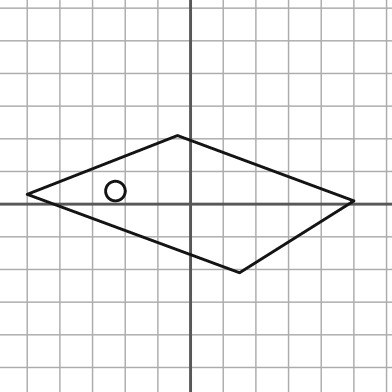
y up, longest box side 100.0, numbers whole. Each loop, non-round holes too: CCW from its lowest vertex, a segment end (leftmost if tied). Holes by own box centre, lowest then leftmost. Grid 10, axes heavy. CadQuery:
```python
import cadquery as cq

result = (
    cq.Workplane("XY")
    .moveTo(15.0, -21.0)
    .lineTo(50.0, 1.0)
    .lineTo(-4.0, 21.0)
    .lineTo(-50.0, 3.0)
    .close()
    .moveTo(-23.0, 4.0)
    .circle(3.0)
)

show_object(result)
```